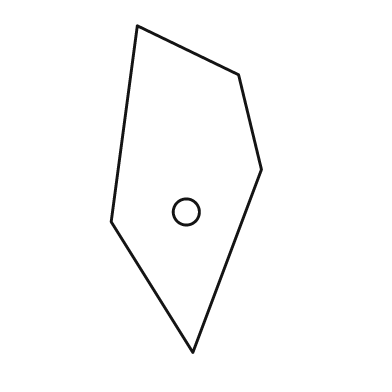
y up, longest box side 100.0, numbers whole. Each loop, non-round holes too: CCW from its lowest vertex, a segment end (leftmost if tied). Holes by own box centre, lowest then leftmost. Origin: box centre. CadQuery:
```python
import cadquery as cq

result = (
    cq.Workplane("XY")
    .moveTo(2.0, -50.0)
    .lineTo(23.0, 6.0)
    .lineTo(16.0, 35.0)
    .lineTo(-15.0, 50.0)
    .lineTo(-23.0, -10.0)
    .close()
    .moveTo(0.0, -7.0)
    .circle(4.0)
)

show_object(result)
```